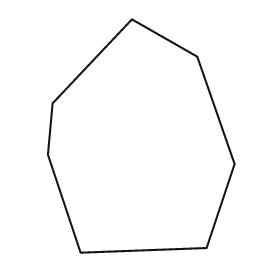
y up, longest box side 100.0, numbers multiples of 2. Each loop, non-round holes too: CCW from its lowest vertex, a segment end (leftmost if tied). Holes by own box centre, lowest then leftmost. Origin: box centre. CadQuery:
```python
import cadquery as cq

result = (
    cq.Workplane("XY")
    .moveTo(-26.0, -50.0)
    .lineTo(28.0, -48.0)
    .lineTo(40.0, -12.0)
    .lineTo(24.0, 34.0)
    .lineTo(-4.0, 50.0)
    .lineTo(-38.0, 14.0)
    .lineTo(-40.0, -8.0)
    .close()
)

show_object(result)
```